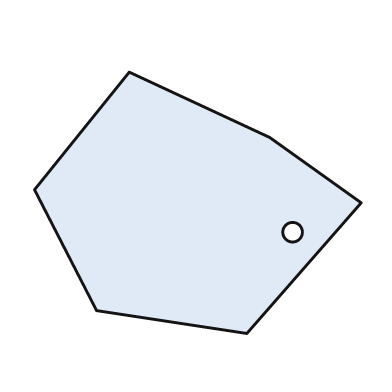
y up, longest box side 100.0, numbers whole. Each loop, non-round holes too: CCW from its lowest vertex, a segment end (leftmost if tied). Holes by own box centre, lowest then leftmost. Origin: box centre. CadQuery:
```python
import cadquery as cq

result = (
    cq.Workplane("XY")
    .moveTo(15.0, -40.0)
    .lineTo(50.0, 0.0)
    .lineTo(22.0, 20.0)
    .lineTo(-21.0, 40.0)
    .lineTo(-50.0, 4.0)
    .lineTo(-31.0, -33.0)
    .close()
    .moveTo(29.0, -9.0)
    .circle(3.0)
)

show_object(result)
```